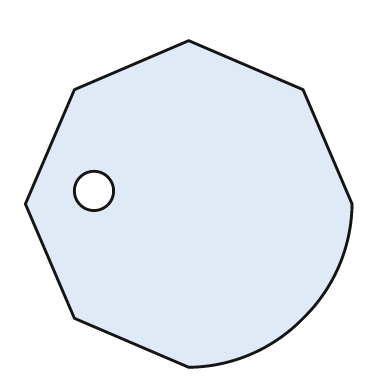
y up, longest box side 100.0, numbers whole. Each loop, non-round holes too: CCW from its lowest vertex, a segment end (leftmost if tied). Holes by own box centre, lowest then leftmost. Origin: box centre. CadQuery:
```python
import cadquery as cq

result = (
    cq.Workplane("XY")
    .moveTo(0.0, -50.0)
    .threePointArc((19.0, -46.0), (35.0, -35.0))
    .threePointArc((46.0, -19.0), (50.0, 0.0))
    .lineTo(35.0, 35.0)
    .lineTo(0.0, 50.0)
    .lineTo(-35.0, 35.0)
    .lineTo(-50.0, 0.0)
    .lineTo(-35.0, -35.0)
    .close()
    .moveTo(-29.0, 4.0)
    .circle(6.0)
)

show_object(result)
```